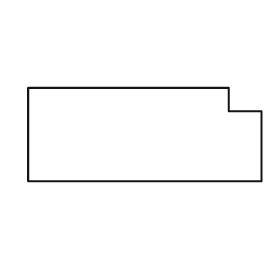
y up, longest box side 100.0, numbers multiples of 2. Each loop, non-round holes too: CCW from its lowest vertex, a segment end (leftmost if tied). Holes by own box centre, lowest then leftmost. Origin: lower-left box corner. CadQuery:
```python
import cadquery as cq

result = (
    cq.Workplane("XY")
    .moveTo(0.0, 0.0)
    .lineTo(100.0, 0.0)
    .lineTo(100.0, 30.0)
    .lineTo(86.0, 30.0)
    .lineTo(86.0, 40.0)
    .lineTo(0.0, 40.0)
    .close()
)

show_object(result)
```